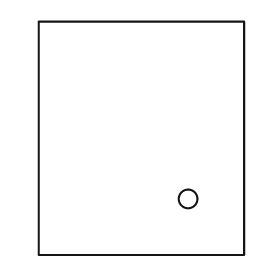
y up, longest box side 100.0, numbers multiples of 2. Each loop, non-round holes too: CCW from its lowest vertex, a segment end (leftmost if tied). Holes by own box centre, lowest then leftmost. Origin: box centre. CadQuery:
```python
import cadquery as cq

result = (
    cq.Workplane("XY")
    .moveTo(-44.0, -50.0)
    .lineTo(44.0, -50.0)
    .lineTo(44.0, 50.0)
    .lineTo(-44.0, 50.0)
    .close()
    .moveTo(20.0, -26.0)
    .circle(4.0)
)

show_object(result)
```